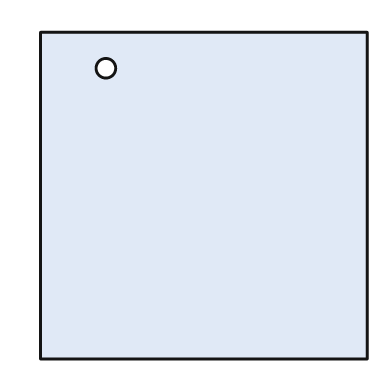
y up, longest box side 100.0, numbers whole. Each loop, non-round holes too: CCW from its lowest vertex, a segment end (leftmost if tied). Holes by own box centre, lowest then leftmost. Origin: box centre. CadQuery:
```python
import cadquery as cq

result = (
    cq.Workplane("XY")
    .moveTo(-50.0, -50.0)
    .lineTo(50.0, -50.0)
    .lineTo(50.0, 50.0)
    .lineTo(-50.0, 50.0)
    .close()
    .moveTo(-30.0, 39.0)
    .circle(3.0)
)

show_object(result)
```